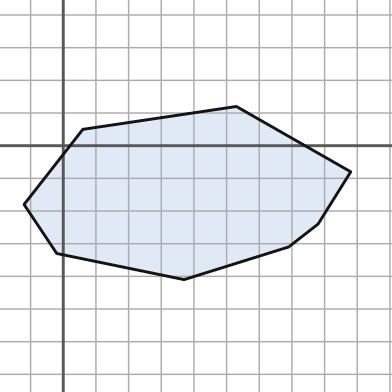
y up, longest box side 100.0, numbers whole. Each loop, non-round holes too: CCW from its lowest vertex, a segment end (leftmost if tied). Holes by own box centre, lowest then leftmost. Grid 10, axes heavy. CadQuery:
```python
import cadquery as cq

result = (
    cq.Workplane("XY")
    .moveTo(37.0, -41.0)
    .lineTo(69.0, -31.0)
    .lineTo(78.0, -24.0)
    .lineTo(88.0, -8.0)
    .lineTo(53.0, 12.0)
    .lineTo(6.0, 5.0)
    .lineTo(-12.0, -18.0)
    .lineTo(-2.0, -33.0)
    .close()
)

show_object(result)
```